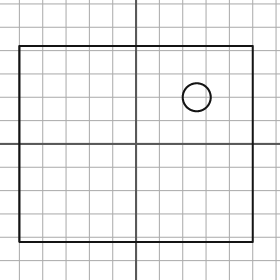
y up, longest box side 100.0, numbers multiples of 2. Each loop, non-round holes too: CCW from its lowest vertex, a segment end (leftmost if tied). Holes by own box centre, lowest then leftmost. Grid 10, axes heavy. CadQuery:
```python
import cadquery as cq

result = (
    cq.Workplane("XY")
    .moveTo(-50.0, -42.0)
    .lineTo(50.0, -42.0)
    .lineTo(50.0, 42.0)
    .lineTo(-50.0, 42.0)
    .close()
    .moveTo(26.0, 20.0)
    .circle(6.0)
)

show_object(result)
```